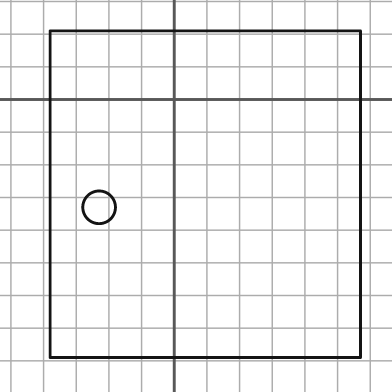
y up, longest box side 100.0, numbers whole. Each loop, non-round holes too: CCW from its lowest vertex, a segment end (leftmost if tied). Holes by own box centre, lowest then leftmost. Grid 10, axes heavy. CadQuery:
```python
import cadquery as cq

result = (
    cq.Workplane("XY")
    .moveTo(-38.0, -79.0)
    .lineTo(57.0, -79.0)
    .lineTo(57.0, 21.0)
    .lineTo(-38.0, 21.0)
    .close()
    .moveTo(-23.0, -33.0)
    .circle(5.0)
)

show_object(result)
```